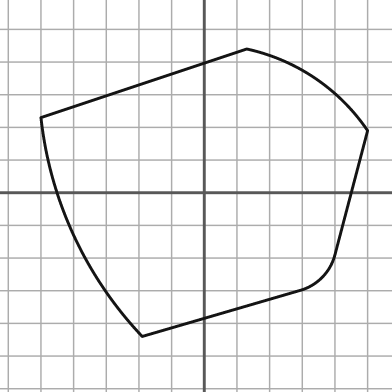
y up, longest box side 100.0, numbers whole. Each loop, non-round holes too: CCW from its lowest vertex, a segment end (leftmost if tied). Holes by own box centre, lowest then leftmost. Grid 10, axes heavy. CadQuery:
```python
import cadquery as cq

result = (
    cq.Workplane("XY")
    .moveTo(-19.0, -44.0)
    .lineTo(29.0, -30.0)
    .threePointArc((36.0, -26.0), (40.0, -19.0))
    .lineTo(50.0, 19.0)
    .threePointArc((34.0, 35.0), (13.0, 44.0))
    .lineTo(-50.0, 23.0)
    .threePointArc((-40.0, -13.0), (-19.0, -44.0))
    .close()
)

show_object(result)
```